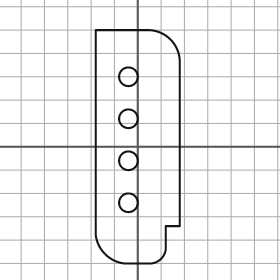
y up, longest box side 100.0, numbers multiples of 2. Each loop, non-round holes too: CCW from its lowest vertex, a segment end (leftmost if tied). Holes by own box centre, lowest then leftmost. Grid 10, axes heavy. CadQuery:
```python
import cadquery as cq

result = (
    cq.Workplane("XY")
    .moveTo(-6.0, -50.0)
    .lineTo(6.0, -50.0)
    .threePointArc((10.0, -48.0), (12.0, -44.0))
    .lineTo(12.0, -34.0)
    .lineTo(18.0, -34.0)
    .lineTo(18.0, 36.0)
    .threePointArc((14.0, 46.0), (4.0, 50.0))
    .lineTo(-18.0, 50.0)
    .lineTo(-18.0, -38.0)
    .threePointArc((-14.0, -46.0), (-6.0, -50.0))
    .close()
    .moveTo(-4.0, -24.0)
    .circle(4.0)
    .moveTo(-4.0, -6.0)
    .circle(4.0)
    .moveTo(-4.0, 12.0)
    .circle(4.0)
    .moveTo(-4.0, 30.0)
    .circle(4.0)
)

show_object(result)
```